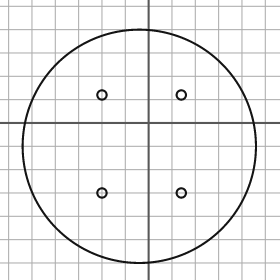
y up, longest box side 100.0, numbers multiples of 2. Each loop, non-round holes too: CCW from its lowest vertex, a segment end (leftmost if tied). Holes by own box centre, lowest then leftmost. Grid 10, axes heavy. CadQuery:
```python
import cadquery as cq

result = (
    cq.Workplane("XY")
    .moveTo(-4.0, -10.0)
    .circle(50.0)
    .moveTo(-20.0, -30.0)
    .circle(2.0)
    .moveTo(14.0, -30.0)
    .circle(2.0)
    .moveTo(-20.0, 12.0)
    .circle(2.0)
    .moveTo(14.0, 12.0)
    .circle(2.0)
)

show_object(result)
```